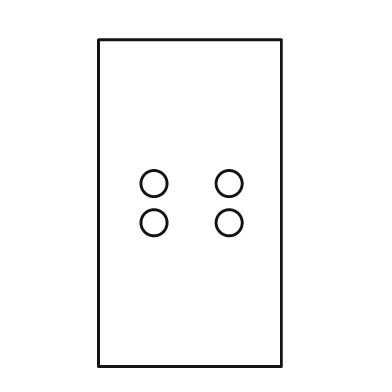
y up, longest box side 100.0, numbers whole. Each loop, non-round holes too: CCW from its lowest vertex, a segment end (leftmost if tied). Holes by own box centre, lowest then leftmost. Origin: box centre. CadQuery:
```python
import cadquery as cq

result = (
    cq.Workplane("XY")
    .moveTo(-28.0, -50.0)
    .lineTo(28.0, -50.0)
    .lineTo(28.0, 50.0)
    .lineTo(-28.0, 50.0)
    .close()
    .moveTo(-11.0, -6.0)
    .circle(4.0)
    .moveTo(12.0, -6.0)
    .circle(4.0)
    .moveTo(-11.0, 6.0)
    .circle(4.0)
    .moveTo(12.0, 6.0)
    .circle(4.0)
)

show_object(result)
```